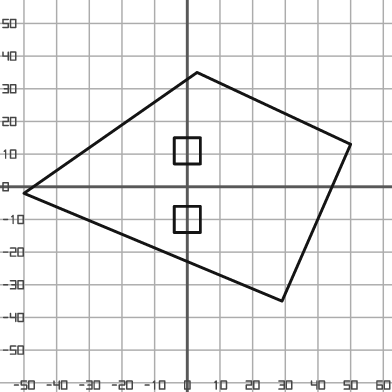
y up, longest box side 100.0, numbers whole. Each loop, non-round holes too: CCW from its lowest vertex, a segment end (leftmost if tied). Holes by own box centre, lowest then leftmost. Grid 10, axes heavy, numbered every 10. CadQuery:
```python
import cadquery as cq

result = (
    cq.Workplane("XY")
    .moveTo(29.0, -35.0)
    .lineTo(50.0, 13.0)
    .lineTo(3.0, 35.0)
    .lineTo(-50.0, -2.0)
    .close()
    .moveTo(-4.0, -14.0)
    .lineTo(4.0, -14.0)
    .lineTo(4.0, -6.0)
    .lineTo(-4.0, -6.0)
    .close()
    .moveTo(-4.0, 7.0)
    .lineTo(4.0, 7.0)
    .lineTo(4.0, 15.0)
    .lineTo(-4.0, 15.0)
    .close()
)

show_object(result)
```